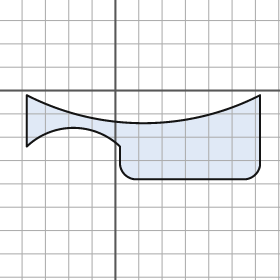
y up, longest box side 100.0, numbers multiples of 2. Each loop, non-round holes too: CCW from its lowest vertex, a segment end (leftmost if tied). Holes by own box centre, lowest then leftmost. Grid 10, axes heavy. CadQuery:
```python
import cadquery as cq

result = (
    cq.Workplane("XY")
    .moveTo(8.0, -38.0)
    .lineTo(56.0, -38.0)
    .threePointArc((60.0, -36.0), (62.0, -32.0))
    .lineTo(62.0, -2.0)
    .threePointArc((12.0, -14.0), (-38.0, -2.0))
    .lineTo(-38.0, -24.0)
    .threePointArc((-18.0, -16.0), (2.0, -24.0))
    .lineTo(2.0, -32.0)
    .threePointArc((4.0, -36.0), (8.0, -38.0))
    .close()
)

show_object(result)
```